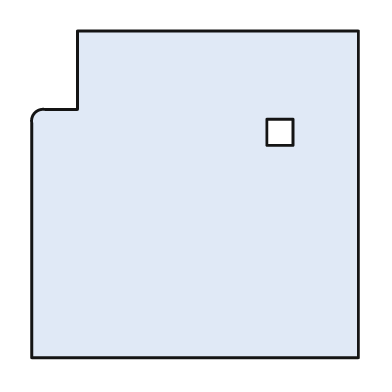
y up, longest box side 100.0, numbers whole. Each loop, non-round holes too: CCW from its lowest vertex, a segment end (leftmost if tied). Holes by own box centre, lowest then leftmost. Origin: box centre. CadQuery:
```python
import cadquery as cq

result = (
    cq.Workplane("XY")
    .moveTo(-50.0, -50.0)
    .lineTo(50.0, -50.0)
    .lineTo(50.0, 50.0)
    .lineTo(-36.0, 50.0)
    .lineTo(-36.0, 26.0)
    .lineTo(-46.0, 26.0)
    .threePointArc((-49.0, 25.0), (-50.0, 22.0))
    .close()
    .moveTo(22.0, 15.0)
    .lineTo(30.0, 15.0)
    .lineTo(30.0, 23.0)
    .lineTo(22.0, 23.0)
    .close()
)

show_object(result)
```